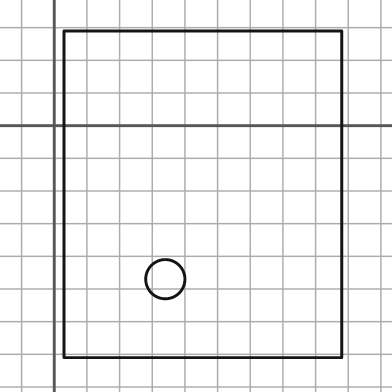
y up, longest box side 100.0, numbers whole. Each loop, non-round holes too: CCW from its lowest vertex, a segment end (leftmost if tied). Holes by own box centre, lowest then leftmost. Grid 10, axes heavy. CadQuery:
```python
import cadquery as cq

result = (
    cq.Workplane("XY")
    .moveTo(3.0, -71.0)
    .lineTo(88.0, -71.0)
    .lineTo(88.0, 29.0)
    .lineTo(3.0, 29.0)
    .close()
    .moveTo(34.0, -47.0)
    .circle(6.0)
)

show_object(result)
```